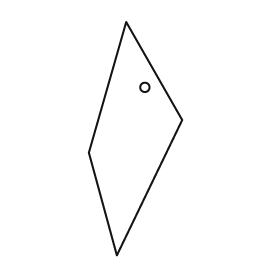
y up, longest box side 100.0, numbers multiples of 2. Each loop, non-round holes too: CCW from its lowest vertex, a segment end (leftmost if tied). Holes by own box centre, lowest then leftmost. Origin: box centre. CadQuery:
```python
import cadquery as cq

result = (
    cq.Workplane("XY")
    .moveTo(-8.0, -50.0)
    .lineTo(20.0, 8.0)
    .lineTo(-4.0, 50.0)
    .lineTo(-20.0, -6.0)
    .close()
    .moveTo(4.0, 22.0)
    .circle(2.0)
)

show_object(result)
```